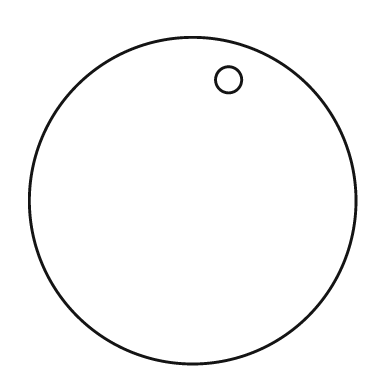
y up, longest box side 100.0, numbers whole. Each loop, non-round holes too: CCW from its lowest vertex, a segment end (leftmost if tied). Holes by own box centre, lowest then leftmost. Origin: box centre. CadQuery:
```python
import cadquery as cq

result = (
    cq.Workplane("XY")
    .moveTo(0.0, 0.0)
    .circle(50.0)
    .moveTo(11.0, 37.0)
    .circle(4.0)
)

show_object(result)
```